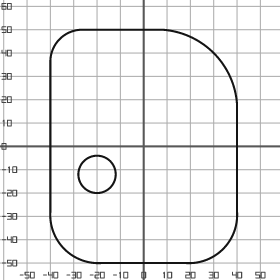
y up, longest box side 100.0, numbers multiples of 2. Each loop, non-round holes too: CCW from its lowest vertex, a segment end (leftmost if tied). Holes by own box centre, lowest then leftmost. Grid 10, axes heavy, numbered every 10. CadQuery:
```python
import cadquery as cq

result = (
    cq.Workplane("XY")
    .moveTo(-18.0, -50.0)
    .lineTo(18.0, -50.0)
    .threePointArc((34.0, -44.0), (40.0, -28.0))
    .lineTo(40.0, 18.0)
    .threePointArc((30.0, 40.0), (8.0, 50.0))
    .lineTo(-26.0, 50.0)
    .threePointArc((-36.0, 46.0), (-40.0, 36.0))
    .lineTo(-40.0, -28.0)
    .threePointArc((-34.0, -44.0), (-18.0, -50.0))
    .close()
    .moveTo(-20.0, -12.0)
    .circle(8.0)
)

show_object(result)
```